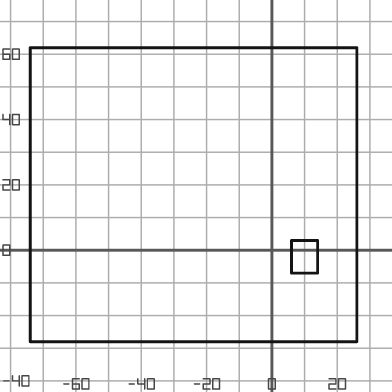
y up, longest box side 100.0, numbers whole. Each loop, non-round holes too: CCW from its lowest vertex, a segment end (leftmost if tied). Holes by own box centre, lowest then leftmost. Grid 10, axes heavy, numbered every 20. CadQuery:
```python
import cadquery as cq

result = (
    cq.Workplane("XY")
    .moveTo(-74.0, -28.0)
    .lineTo(26.0, -28.0)
    .lineTo(26.0, 62.0)
    .lineTo(-74.0, 62.0)
    .close()
    .moveTo(6.0, -7.0)
    .lineTo(14.0, -7.0)
    .lineTo(14.0, 3.0)
    .lineTo(6.0, 3.0)
    .close()
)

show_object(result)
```